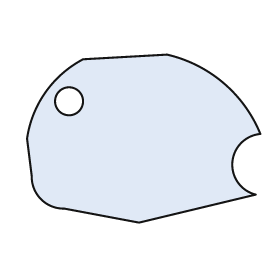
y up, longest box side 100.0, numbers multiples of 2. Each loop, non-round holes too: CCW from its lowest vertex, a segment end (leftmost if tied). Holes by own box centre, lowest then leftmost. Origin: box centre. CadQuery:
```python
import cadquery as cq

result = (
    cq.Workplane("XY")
    .moveTo(-2.0, -36.0)
    .lineTo(48.0, -24.0)
    .threePointArc((38.0, -10.0), (50.0, 2.0))
    .threePointArc((34.0, 24.0), (10.0, 36.0))
    .lineTo(-26.0, 34.0)
    .threePointArc((-42.0, 20.0), (-50.0, 0.0))
    .lineTo(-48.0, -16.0)
    .threePointArc((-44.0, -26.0), (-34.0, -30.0))
    .close()
    .moveTo(-32.0, 16.0)
    .circle(6.0)
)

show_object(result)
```